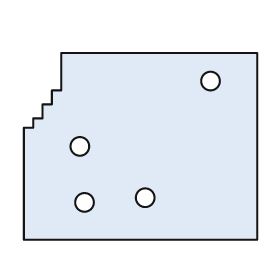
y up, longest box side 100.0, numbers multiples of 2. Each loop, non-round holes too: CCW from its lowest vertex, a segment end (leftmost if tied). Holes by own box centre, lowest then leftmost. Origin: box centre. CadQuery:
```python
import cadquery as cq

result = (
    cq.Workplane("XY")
    .moveTo(-50.0, -40.0)
    .lineTo(50.0, -40.0)
    .lineTo(50.0, 40.0)
    .lineTo(-34.0, 40.0)
    .lineTo(-34.0, 24.0)
    .lineTo(-38.0, 24.0)
    .lineTo(-38.0, 18.0)
    .lineTo(-42.0, 18.0)
    .lineTo(-42.0, 12.0)
    .lineTo(-46.0, 12.0)
    .lineTo(-46.0, 8.0)
    .lineTo(-50.0, 8.0)
    .close()
    .moveTo(-24.0, -24.0)
    .circle(4.0)
    .moveTo(2.0, -22.0)
    .circle(4.0)
    .moveTo(-26.0, 0.0)
    .circle(4.0)
    .moveTo(30.0, 28.0)
    .circle(4.0)
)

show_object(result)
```